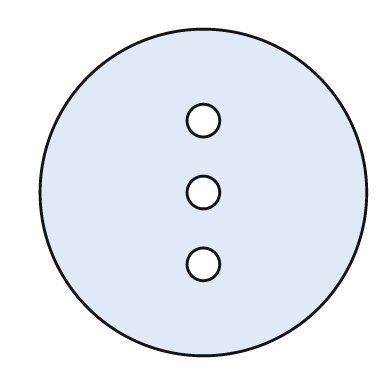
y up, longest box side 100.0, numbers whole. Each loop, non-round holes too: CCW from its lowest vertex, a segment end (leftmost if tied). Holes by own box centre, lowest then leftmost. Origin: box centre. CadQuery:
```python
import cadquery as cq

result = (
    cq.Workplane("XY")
    .moveTo(0.0, 0.0)
    .circle(50.0)
    .moveTo(0.0, -22.0)
    .circle(5.0)
    .moveTo(0.0, 0.0)
    .circle(5.0)
    .moveTo(0.0, 22.0)
    .circle(5.0)
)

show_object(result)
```